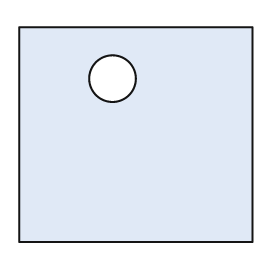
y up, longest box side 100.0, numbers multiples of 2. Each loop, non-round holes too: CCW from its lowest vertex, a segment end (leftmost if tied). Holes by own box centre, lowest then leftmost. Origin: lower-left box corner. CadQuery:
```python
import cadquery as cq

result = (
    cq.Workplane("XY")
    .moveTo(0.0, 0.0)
    .lineTo(100.0, 0.0)
    .lineTo(100.0, 92.0)
    .lineTo(0.0, 92.0)
    .close()
    .moveTo(40.0, 70.0)
    .circle(10.0)
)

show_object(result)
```